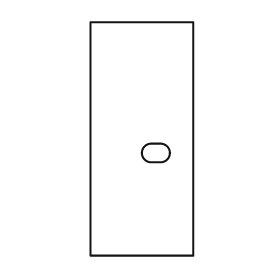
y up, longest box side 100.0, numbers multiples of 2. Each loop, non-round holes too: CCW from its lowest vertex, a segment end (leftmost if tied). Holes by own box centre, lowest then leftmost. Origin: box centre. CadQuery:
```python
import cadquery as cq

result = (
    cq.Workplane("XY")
    .moveTo(-22.0, -50.0)
    .lineTo(22.0, -50.0)
    .lineTo(22.0, 50.0)
    .lineTo(-22.0, 50.0)
    .close()
    .moveTo(4.0, -10.0)
    .lineTo(8.0, -10.0)
    .threePointArc((12.0, -6.0), (8.0, -2.0))
    .lineTo(4.0, -2.0)
    .threePointArc((0.0, -6.0), (4.0, -10.0))
    .close()
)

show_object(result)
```